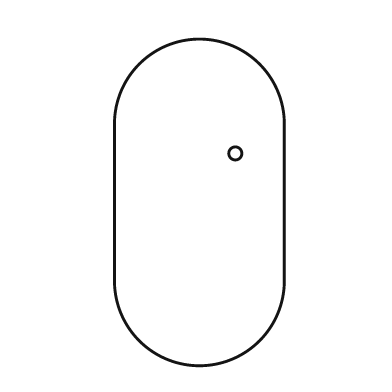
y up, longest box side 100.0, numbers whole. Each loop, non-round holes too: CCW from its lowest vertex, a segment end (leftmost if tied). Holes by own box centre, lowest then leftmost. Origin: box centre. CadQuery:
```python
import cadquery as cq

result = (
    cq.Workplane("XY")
    .moveTo(-26.0, -24.0)
    .threePointArc((0.0, -50.0), (26.0, -24.0))
    .lineTo(26.0, 24.0)
    .threePointArc((0.0, 50.0), (-26.0, 24.0))
    .close()
    .moveTo(11.0, 15.0)
    .circle(2.0)
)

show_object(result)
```